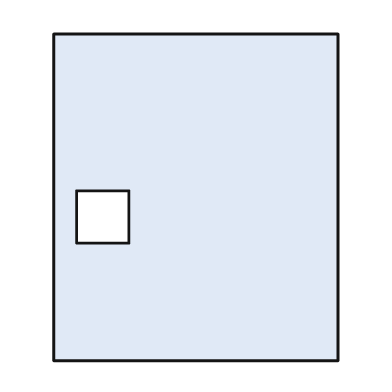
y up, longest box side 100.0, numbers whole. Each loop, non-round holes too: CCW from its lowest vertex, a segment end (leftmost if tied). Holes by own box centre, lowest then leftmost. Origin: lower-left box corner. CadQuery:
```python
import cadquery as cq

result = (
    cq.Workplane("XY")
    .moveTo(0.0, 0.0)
    .lineTo(87.0, 0.0)
    .lineTo(87.0, 100.0)
    .lineTo(0.0, 100.0)
    .close()
    .moveTo(7.0, 36.0)
    .lineTo(23.0, 36.0)
    .lineTo(23.0, 52.0)
    .lineTo(7.0, 52.0)
    .close()
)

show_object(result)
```